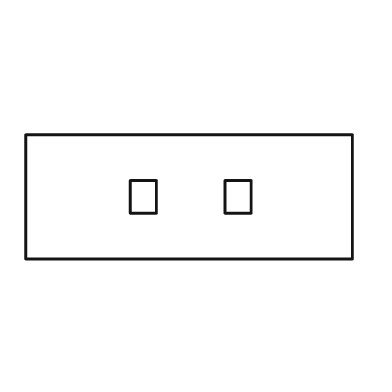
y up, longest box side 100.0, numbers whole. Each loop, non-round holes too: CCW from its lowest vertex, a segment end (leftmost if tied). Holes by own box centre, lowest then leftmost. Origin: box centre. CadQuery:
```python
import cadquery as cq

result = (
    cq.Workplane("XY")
    .moveTo(-50.0, -19.0)
    .lineTo(50.0, -19.0)
    .lineTo(50.0, 19.0)
    .lineTo(-50.0, 19.0)
    .close()
    .moveTo(-18.0, -5.0)
    .lineTo(-10.0, -5.0)
    .lineTo(-10.0, 5.0)
    .lineTo(-18.0, 5.0)
    .close()
    .moveTo(11.0, -5.0)
    .lineTo(19.0, -5.0)
    .lineTo(19.0, 5.0)
    .lineTo(11.0, 5.0)
    .close()
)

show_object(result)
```